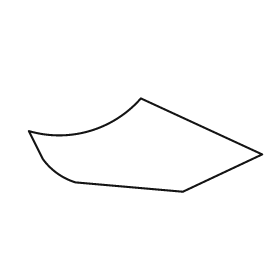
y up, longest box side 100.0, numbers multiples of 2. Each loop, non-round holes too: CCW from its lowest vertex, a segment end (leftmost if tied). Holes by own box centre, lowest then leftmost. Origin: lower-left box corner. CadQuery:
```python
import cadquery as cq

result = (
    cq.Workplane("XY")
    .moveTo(66.0, 0.0)
    .lineTo(100.0, 16.0)
    .lineTo(48.0, 40.0)
    .threePointArc((26.0, 26.0), (0.0, 26.0))
    .lineTo(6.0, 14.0)
    .threePointArc((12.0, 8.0), (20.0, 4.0))
    .close()
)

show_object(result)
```